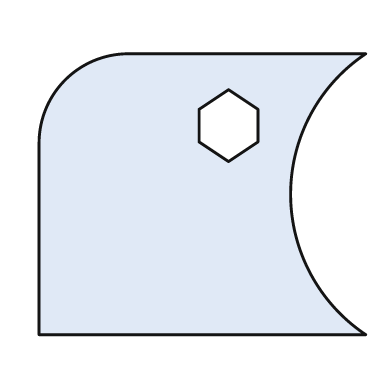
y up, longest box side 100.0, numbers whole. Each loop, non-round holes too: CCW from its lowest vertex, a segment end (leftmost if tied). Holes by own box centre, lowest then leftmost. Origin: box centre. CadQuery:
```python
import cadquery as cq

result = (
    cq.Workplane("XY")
    .moveTo(-50.0, -43.0)
    .lineTo(50.0, -43.0)
    .threePointArc((27.0, 0.0), (50.0, 43.0))
    .lineTo(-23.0, 43.0)
    .threePointArc((-42.0, 35.0), (-50.0, 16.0))
    .close()
    .moveTo(8.0, 10.0)
    .lineTo(17.0, 16.0)
    .lineTo(17.0, 26.0)
    .lineTo(8.0, 32.0)
    .lineTo(-1.0, 26.0)
    .lineTo(-1.0, 16.0)
    .close()
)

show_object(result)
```